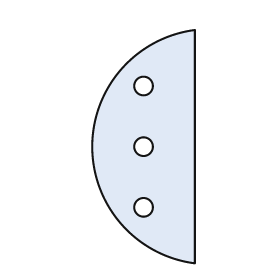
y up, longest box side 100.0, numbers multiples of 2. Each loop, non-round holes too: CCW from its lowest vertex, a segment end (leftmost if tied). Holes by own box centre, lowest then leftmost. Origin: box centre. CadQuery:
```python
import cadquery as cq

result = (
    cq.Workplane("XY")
    .moveTo(22.0, -50.0)
    .lineTo(22.0, 50.0)
    .threePointArc((-22.0, 0.0), (22.0, -50.0))
    .close()
    .moveTo(0.0, -26.0)
    .circle(4.0)
    .moveTo(0.0, 0.0)
    .circle(4.0)
    .moveTo(0.0, 26.0)
    .circle(4.0)
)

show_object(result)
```